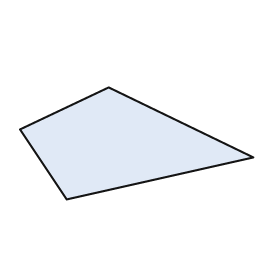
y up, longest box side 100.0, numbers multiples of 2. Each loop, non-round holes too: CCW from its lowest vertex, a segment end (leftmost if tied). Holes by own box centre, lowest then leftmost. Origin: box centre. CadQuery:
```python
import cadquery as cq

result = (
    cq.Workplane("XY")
    .moveTo(-30.0, -24.0)
    .lineTo(50.0, -6.0)
    .lineTo(-12.0, 24.0)
    .lineTo(-50.0, 6.0)
    .close()
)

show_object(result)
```